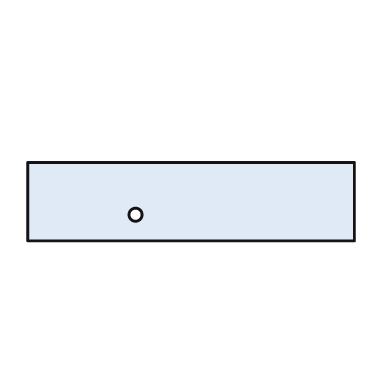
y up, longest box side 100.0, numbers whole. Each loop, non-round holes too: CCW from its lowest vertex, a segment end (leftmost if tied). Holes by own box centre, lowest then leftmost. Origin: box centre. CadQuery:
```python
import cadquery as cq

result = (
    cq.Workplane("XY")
    .moveTo(-50.0, -12.0)
    .lineTo(50.0, -12.0)
    .lineTo(50.0, 12.0)
    .lineTo(-50.0, 12.0)
    .close()
    .moveTo(-17.0, -4.0)
    .circle(2.0)
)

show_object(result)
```